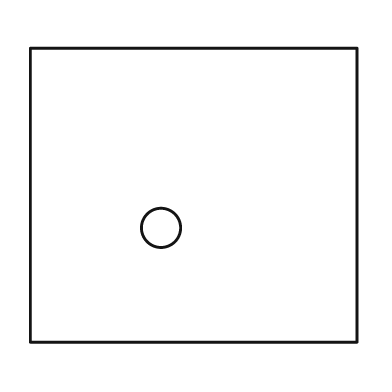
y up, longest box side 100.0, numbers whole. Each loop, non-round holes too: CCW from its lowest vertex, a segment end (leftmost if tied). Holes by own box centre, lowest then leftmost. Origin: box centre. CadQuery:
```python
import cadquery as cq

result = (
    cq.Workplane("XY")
    .moveTo(-50.0, -45.0)
    .lineTo(50.0, -45.0)
    .lineTo(50.0, 45.0)
    .lineTo(-50.0, 45.0)
    .close()
    .moveTo(-10.0, -10.0)
    .circle(6.0)
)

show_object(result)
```